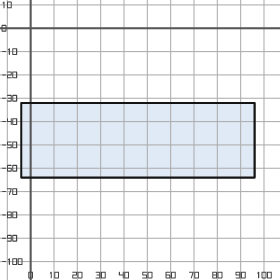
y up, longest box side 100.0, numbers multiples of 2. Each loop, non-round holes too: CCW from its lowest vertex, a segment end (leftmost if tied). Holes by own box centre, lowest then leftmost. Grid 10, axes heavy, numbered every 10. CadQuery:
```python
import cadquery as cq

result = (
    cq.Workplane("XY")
    .moveTo(-4.0, -64.0)
    .lineTo(96.0, -64.0)
    .lineTo(96.0, -32.0)
    .lineTo(-4.0, -32.0)
    .close()
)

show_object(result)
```